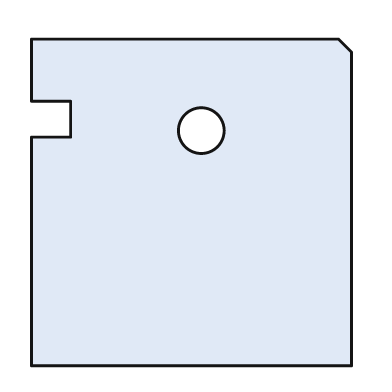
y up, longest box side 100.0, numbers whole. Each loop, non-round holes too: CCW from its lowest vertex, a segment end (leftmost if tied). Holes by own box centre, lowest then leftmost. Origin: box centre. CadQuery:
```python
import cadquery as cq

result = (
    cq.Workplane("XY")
    .moveTo(-49.0, -50.0)
    .lineTo(49.0, -50.0)
    .lineTo(49.0, 46.0)
    .lineTo(45.0, 50.0)
    .lineTo(-49.0, 50.0)
    .lineTo(-49.0, 31.0)
    .lineTo(-37.0, 31.0)
    .lineTo(-37.0, 20.0)
    .lineTo(-49.0, 20.0)
    .close()
    .moveTo(3.0, 22.0)
    .circle(7.0)
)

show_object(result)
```